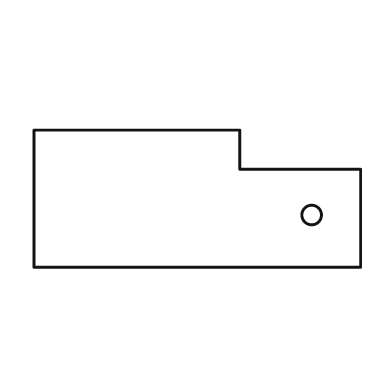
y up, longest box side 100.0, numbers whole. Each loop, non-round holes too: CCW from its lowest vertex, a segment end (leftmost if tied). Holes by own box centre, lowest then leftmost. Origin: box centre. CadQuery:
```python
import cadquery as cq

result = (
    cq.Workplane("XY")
    .moveTo(-50.0, -21.0)
    .lineTo(50.0, -21.0)
    .lineTo(50.0, 9.0)
    .lineTo(13.0, 9.0)
    .lineTo(13.0, 21.0)
    .lineTo(-50.0, 21.0)
    .close()
    .moveTo(35.0, -5.0)
    .circle(3.0)
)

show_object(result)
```